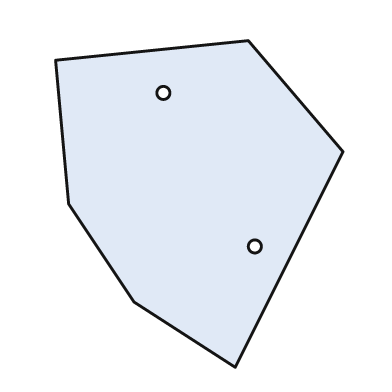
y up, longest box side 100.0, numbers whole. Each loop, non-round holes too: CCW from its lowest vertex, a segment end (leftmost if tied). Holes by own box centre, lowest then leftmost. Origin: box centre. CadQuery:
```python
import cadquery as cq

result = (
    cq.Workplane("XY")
    .moveTo(11.0, -50.0)
    .lineTo(44.0, 16.0)
    .lineTo(15.0, 50.0)
    .lineTo(-44.0, 44.0)
    .lineTo(-40.0, 0.0)
    .lineTo(-20.0, -30.0)
    .close()
    .moveTo(17.0, -13.0)
    .circle(2.0)
    .moveTo(-11.0, 34.0)
    .circle(2.0)
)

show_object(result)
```